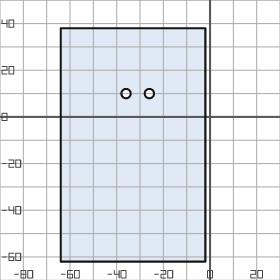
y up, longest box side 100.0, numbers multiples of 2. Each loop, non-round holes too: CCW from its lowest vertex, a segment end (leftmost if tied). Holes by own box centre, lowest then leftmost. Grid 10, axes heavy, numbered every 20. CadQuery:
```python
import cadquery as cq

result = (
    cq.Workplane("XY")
    .moveTo(-64.0, -62.0)
    .lineTo(-2.0, -62.0)
    .lineTo(-2.0, 38.0)
    .lineTo(-64.0, 38.0)
    .close()
    .moveTo(-36.0, 10.0)
    .circle(2.0)
    .moveTo(-26.0, 10.0)
    .circle(2.0)
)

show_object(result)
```